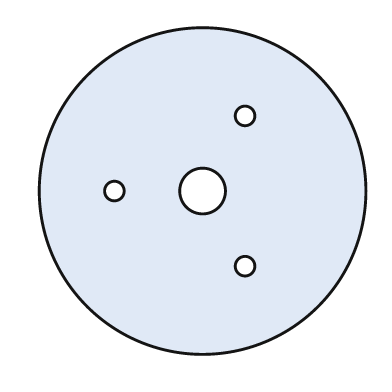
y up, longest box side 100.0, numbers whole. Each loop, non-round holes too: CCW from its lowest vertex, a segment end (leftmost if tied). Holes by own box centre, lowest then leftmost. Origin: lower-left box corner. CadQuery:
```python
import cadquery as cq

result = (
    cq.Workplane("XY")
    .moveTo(50.0, 50.0)
    .circle(50.0)
    .moveTo(63.0, 27.0)
    .circle(3.0)
    .moveTo(23.0, 50.0)
    .circle(3.0)
    .moveTo(50.0, 50.0)
    .circle(7.0)
    .moveTo(63.0, 73.0)
    .circle(3.0)
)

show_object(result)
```